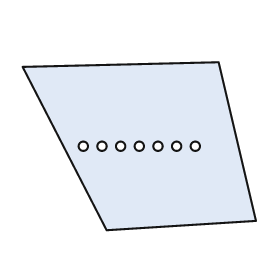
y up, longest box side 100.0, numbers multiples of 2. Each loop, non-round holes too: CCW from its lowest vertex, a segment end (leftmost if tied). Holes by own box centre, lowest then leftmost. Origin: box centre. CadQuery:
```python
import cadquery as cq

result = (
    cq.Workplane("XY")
    .moveTo(-14.0, -36.0)
    .lineTo(50.0, -32.0)
    .lineTo(34.0, 36.0)
    .lineTo(-50.0, 34.0)
    .close()
    .moveTo(-24.0, 0.0)
    .circle(2.0)
    .moveTo(-16.0, 0.0)
    .circle(2.0)
    .moveTo(-8.0, 0.0)
    .circle(2.0)
    .moveTo(0.0, 0.0)
    .circle(2.0)
    .moveTo(8.0, 0.0)
    .circle(2.0)
    .moveTo(16.0, 0.0)
    .circle(2.0)
    .moveTo(24.0, 0.0)
    .circle(2.0)
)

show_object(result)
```